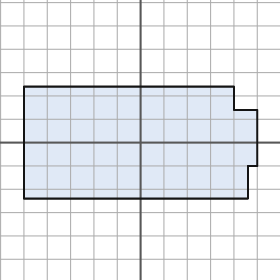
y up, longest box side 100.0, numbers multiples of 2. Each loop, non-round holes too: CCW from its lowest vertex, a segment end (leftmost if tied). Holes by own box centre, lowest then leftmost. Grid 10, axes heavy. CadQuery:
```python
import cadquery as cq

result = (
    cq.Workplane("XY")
    .moveTo(-50.0, -24.0)
    .lineTo(46.0, -24.0)
    .lineTo(46.0, -10.0)
    .lineTo(50.0, -10.0)
    .lineTo(50.0, 14.0)
    .lineTo(40.0, 14.0)
    .lineTo(40.0, 24.0)
    .lineTo(-50.0, 24.0)
    .close()
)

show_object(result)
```